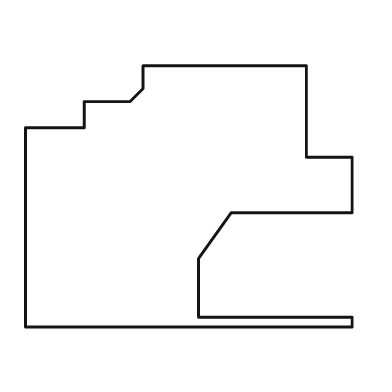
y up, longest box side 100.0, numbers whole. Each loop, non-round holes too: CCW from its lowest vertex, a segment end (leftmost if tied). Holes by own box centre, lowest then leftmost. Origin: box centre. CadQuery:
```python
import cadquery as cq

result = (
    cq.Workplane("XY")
    .moveTo(-50.0, -40.0)
    .lineTo(50.0, -40.0)
    .lineTo(50.0, -37.0)
    .lineTo(3.0, -37.0)
    .lineTo(3.0, -19.0)
    .lineTo(13.0, -5.0)
    .lineTo(50.0, -5.0)
    .lineTo(50.0, 12.0)
    .lineTo(36.0, 12.0)
    .lineTo(36.0, 40.0)
    .lineTo(-14.0, 40.0)
    .lineTo(-14.0, 33.0)
    .lineTo(-18.0, 29.0)
    .lineTo(-32.0, 29.0)
    .lineTo(-32.0, 21.0)
    .lineTo(-50.0, 21.0)
    .close()
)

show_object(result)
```